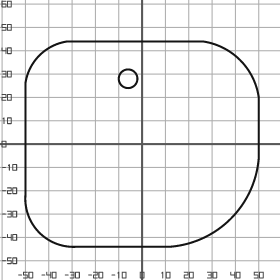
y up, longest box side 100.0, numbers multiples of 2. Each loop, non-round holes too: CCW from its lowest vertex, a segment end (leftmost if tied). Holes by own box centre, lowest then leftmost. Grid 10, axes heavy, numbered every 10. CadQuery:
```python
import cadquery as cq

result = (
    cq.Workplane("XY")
    .moveTo(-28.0, -44.0)
    .lineTo(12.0, -44.0)
    .threePointArc((38.0, -32.0), (50.0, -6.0))
    .lineTo(50.0, 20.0)
    .threePointArc((42.0, 36.0), (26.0, 44.0))
    .lineTo(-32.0, 44.0)
    .threePointArc((-44.0, 38.0), (-50.0, 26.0))
    .lineTo(-50.0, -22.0)
    .threePointArc((-44.0, -38.0), (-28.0, -44.0))
    .close()
    .moveTo(-6.0, 28.0)
    .circle(4.0)
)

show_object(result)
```